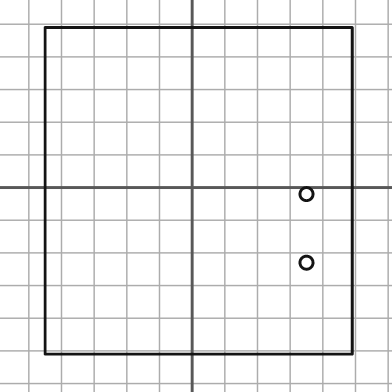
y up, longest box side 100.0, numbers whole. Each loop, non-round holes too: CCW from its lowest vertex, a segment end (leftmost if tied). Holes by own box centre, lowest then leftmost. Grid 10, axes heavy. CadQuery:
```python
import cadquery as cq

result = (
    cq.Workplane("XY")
    .moveTo(-45.0, -51.0)
    .lineTo(49.0, -51.0)
    .lineTo(49.0, 49.0)
    .lineTo(-45.0, 49.0)
    .close()
    .moveTo(35.0, -23.0)
    .circle(2.0)
    .moveTo(35.0, -2.0)
    .circle(2.0)
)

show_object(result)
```